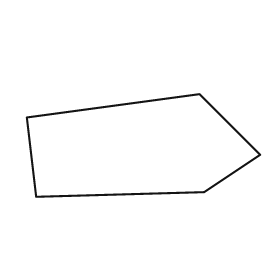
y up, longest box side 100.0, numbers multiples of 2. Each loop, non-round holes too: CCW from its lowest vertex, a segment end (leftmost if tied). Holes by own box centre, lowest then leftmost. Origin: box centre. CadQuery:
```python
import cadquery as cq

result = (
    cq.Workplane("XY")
    .moveTo(-46.0, -22.0)
    .lineTo(26.0, -20.0)
    .lineTo(50.0, -4.0)
    .lineTo(24.0, 22.0)
    .lineTo(-50.0, 12.0)
    .close()
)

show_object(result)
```